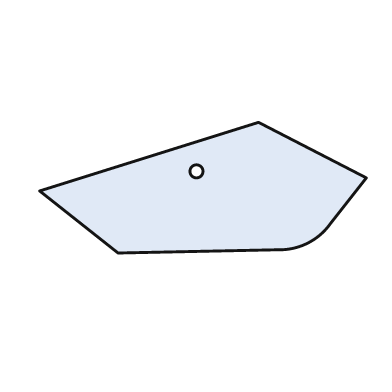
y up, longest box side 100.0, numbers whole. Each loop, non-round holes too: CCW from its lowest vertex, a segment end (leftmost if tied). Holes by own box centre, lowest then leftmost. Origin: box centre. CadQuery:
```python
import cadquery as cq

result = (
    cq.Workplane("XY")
    .moveTo(-26.0, -20.0)
    .lineTo(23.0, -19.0)
    .threePointArc((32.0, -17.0), (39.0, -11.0))
    .lineTo(50.0, 3.0)
    .lineTo(17.0, 20.0)
    .lineTo(-50.0, -1.0)
    .close()
    .moveTo(-2.0, 5.0)
    .circle(2.0)
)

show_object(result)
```